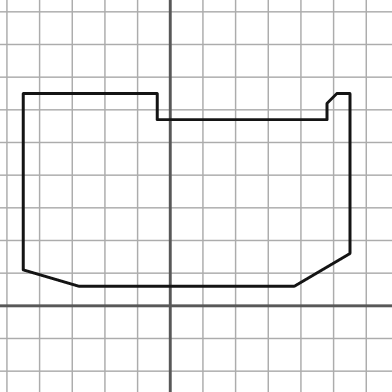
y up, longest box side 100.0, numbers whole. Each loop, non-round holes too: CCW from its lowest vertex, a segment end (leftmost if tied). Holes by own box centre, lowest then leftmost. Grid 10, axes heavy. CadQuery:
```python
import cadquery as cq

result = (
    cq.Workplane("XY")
    .moveTo(-28.0, 6.0)
    .lineTo(38.0, 6.0)
    .lineTo(55.0, 16.0)
    .lineTo(55.0, 65.0)
    .lineTo(51.0, 65.0)
    .lineTo(48.0, 62.0)
    .lineTo(48.0, 57.0)
    .lineTo(-4.0, 57.0)
    .lineTo(-4.0, 65.0)
    .lineTo(-45.0, 65.0)
    .lineTo(-45.0, 11.0)
    .close()
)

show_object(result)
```